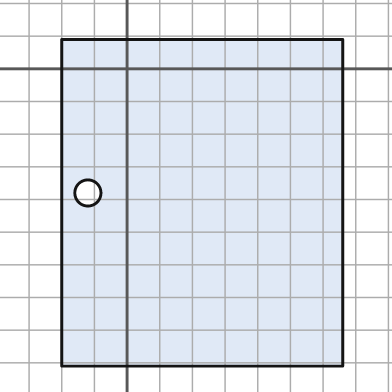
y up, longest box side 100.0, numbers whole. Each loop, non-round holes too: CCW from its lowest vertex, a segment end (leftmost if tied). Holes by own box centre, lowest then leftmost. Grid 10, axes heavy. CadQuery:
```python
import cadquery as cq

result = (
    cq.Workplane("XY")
    .moveTo(-20.0, -91.0)
    .lineTo(66.0, -91.0)
    .lineTo(66.0, 9.0)
    .lineTo(-20.0, 9.0)
    .close()
    .moveTo(-12.0, -38.0)
    .circle(4.0)
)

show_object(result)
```